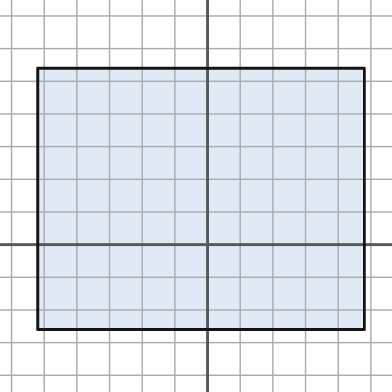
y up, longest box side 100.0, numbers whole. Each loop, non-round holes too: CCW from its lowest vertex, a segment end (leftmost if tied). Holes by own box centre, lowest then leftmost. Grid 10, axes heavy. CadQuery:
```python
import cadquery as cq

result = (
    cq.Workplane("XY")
    .moveTo(-52.0, -26.0)
    .lineTo(48.0, -26.0)
    .lineTo(48.0, 54.0)
    .lineTo(-52.0, 54.0)
    .close()
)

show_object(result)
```